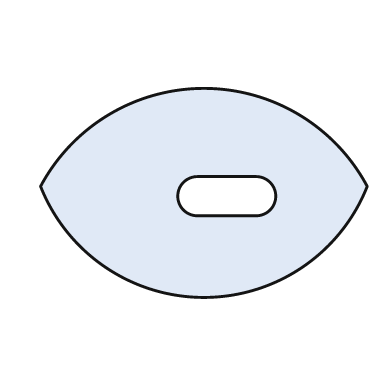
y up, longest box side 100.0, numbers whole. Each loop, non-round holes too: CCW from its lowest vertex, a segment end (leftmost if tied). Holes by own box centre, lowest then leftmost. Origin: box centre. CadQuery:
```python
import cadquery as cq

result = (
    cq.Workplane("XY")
    .moveTo(-50.0, 2.0)
    .threePointArc((0.0, -32.0), (50.0, 2.0))
    .threePointArc((0.0, 32.0), (-50.0, 2.0))
    .close()
    .moveTo(-2.0, -7.0)
    .lineTo(16.0, -7.0)
    .threePointArc((22.0, -1.0), (16.0, 5.0))
    .lineTo(-2.0, 5.0)
    .threePointArc((-8.0, -1.0), (-2.0, -7.0))
    .close()
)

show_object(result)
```